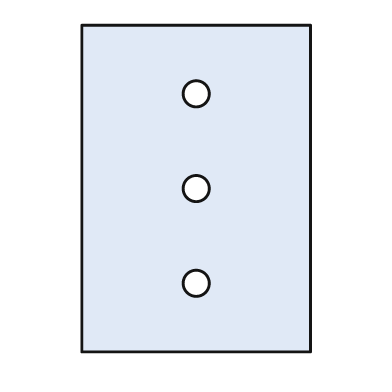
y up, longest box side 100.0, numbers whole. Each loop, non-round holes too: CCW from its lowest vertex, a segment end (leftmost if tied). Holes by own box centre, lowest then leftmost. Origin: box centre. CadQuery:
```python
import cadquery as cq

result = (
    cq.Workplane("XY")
    .moveTo(-35.0, -50.0)
    .lineTo(35.0, -50.0)
    .lineTo(35.0, 50.0)
    .lineTo(-35.0, 50.0)
    .close()
    .moveTo(0.0, -29.0)
    .circle(4.0)
    .moveTo(0.0, 0.0)
    .circle(4.0)
    .moveTo(0.0, 29.0)
    .circle(4.0)
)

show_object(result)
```